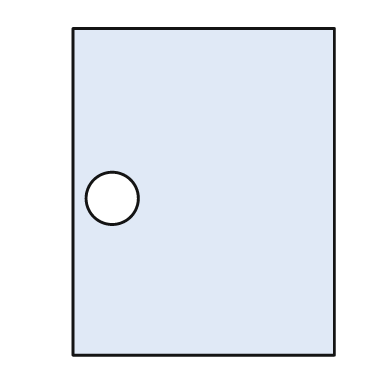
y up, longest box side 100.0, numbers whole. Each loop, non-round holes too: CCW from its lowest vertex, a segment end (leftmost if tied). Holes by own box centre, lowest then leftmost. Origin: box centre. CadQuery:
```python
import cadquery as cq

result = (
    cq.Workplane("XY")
    .moveTo(-40.0, -50.0)
    .lineTo(40.0, -50.0)
    .lineTo(40.0, 50.0)
    .lineTo(-40.0, 50.0)
    .close()
    .moveTo(-28.0, -2.0)
    .circle(8.0)
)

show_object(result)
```